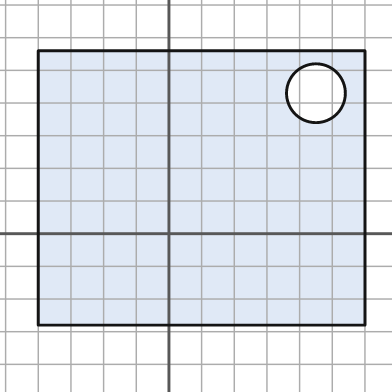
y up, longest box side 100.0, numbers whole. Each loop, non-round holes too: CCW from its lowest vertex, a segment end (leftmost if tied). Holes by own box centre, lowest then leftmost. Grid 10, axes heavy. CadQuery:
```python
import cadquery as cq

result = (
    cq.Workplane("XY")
    .moveTo(-40.0, -28.0)
    .lineTo(60.0, -28.0)
    .lineTo(60.0, 56.0)
    .lineTo(-40.0, 56.0)
    .close()
    .moveTo(45.0, 43.0)
    .circle(9.0)
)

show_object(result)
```